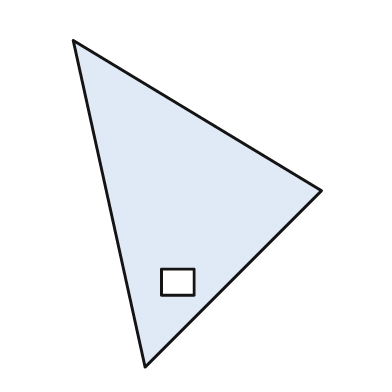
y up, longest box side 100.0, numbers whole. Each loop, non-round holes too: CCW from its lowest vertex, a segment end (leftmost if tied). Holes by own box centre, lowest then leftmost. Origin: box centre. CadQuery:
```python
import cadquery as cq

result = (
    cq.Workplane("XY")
    .moveTo(-16.0, -50.0)
    .lineTo(38.0, 4.0)
    .lineTo(-38.0, 50.0)
    .close()
    .moveTo(-11.0, -28.0)
    .lineTo(-1.0, -28.0)
    .lineTo(-1.0, -20.0)
    .lineTo(-11.0, -20.0)
    .close()
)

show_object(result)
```